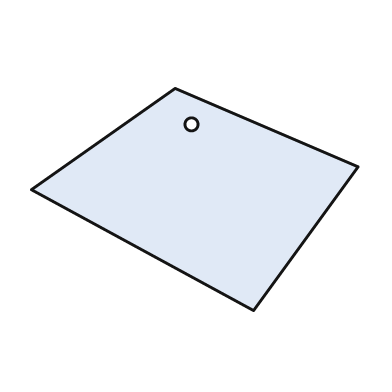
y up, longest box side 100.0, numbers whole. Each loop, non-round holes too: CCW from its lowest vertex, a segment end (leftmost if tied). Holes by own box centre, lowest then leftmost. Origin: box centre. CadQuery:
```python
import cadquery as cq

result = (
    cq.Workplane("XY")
    .moveTo(18.0, -34.0)
    .lineTo(50.0, 10.0)
    .lineTo(-6.0, 34.0)
    .lineTo(-50.0, 3.0)
    .close()
    .moveTo(-1.0, 23.0)
    .circle(2.0)
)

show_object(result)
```